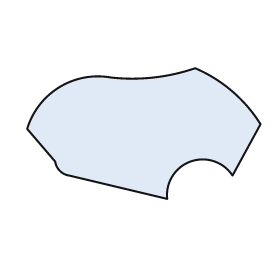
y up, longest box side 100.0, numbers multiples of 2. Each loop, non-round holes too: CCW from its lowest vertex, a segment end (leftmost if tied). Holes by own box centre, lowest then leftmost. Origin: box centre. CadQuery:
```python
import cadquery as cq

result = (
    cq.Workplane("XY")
    .moveTo(10.0, -28.0)
    .threePointArc((20.0, -12.0), (38.0, -18.0))
    .lineTo(50.0, 4.0)
    .threePointArc((38.0, 18.0), (22.0, 28.0))
    .threePointArc((4.0, 24.0), (-14.0, 24.0))
    .threePointArc((-36.0, 20.0), (-50.0, 2.0))
    .lineTo(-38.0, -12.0)
    .threePointArc((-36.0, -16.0), (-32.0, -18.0))
    .close()
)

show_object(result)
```